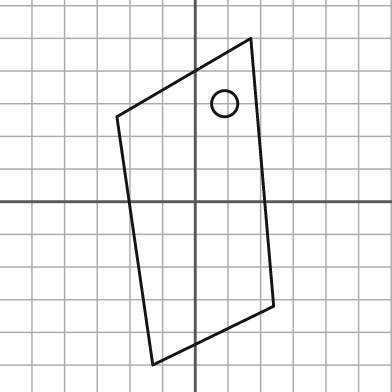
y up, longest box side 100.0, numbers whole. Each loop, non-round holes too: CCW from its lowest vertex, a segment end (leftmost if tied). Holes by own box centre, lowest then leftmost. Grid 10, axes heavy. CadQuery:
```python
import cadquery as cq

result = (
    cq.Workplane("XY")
    .moveTo(-13.0, -50.0)
    .lineTo(24.0, -32.0)
    .lineTo(17.0, 50.0)
    .lineTo(-24.0, 26.0)
    .close()
    .moveTo(9.0, 30.0)
    .circle(4.0)
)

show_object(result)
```